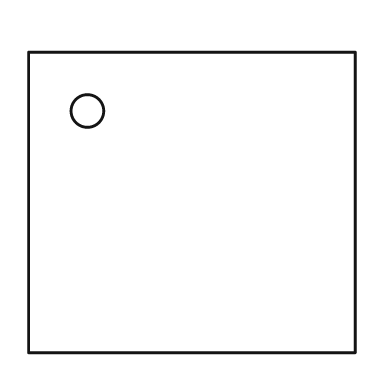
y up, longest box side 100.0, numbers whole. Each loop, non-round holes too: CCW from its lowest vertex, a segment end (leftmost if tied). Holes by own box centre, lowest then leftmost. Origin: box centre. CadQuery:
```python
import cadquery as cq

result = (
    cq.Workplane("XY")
    .moveTo(-50.0, -46.0)
    .lineTo(50.0, -46.0)
    .lineTo(50.0, 46.0)
    .lineTo(-50.0, 46.0)
    .close()
    .moveTo(-32.0, 28.0)
    .circle(5.0)
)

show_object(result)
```